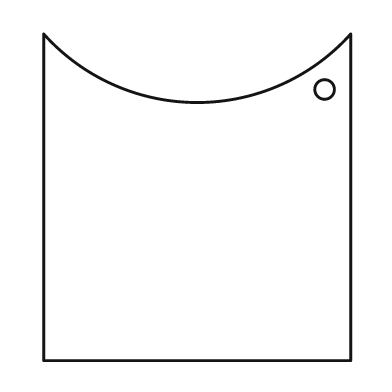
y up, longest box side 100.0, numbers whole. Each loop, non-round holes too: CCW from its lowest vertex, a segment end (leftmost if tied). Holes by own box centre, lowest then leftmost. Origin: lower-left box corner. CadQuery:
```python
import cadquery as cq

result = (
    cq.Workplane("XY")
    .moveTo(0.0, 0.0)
    .lineTo(94.0, 0.0)
    .lineTo(94.0, 100.0)
    .threePointArc((47.0, 79.0), (0.0, 100.0))
    .close()
    .moveTo(86.0, 83.0)
    .circle(3.0)
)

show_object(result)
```